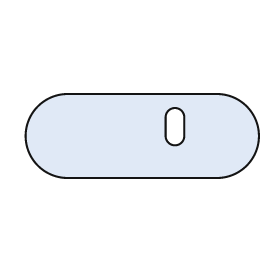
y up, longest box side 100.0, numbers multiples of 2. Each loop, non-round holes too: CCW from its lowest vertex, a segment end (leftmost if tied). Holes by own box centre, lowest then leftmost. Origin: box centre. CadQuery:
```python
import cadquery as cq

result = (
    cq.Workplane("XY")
    .moveTo(-32.0, -18.0)
    .lineTo(32.0, -18.0)
    .threePointArc((50.0, 0.0), (32.0, 18.0))
    .lineTo(-32.0, 18.0)
    .threePointArc((-50.0, 0.0), (-32.0, -18.0))
    .close()
    .moveTo(10.0, 0.0)
    .threePointArc((14.0, -4.0), (18.0, 0.0))
    .lineTo(18.0, 8.0)
    .threePointArc((14.0, 12.0), (10.0, 8.0))
    .close()
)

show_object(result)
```